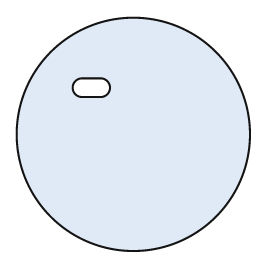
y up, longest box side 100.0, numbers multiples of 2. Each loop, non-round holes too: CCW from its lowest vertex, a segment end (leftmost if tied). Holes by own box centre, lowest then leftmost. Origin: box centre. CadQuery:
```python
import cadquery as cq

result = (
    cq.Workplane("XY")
    .moveTo(0.0, 0.0)
    .circle(50.0)
    .moveTo(-22.0, 16.0)
    .lineTo(-14.0, 16.0)
    .threePointArc((-10.0, 20.0), (-14.0, 24.0))
    .lineTo(-22.0, 24.0)
    .threePointArc((-26.0, 20.0), (-22.0, 16.0))
    .close()
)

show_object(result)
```